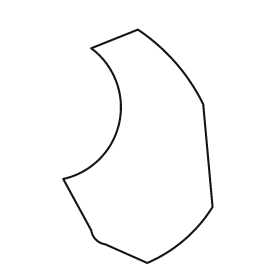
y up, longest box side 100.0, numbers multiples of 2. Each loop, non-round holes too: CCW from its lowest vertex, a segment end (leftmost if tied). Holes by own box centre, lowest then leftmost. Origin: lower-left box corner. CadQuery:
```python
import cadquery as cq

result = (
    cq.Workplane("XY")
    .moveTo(36.0, 0.0)
    .threePointArc((52.0, 10.0), (64.0, 24.0))
    .lineTo(60.0, 68.0)
    .threePointArc((48.0, 86.0), (32.0, 100.0))
    .lineTo(12.0, 92.0)
    .threePointArc((24.0, 60.0), (0.0, 36.0))
    .lineTo(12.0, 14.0)
    .threePointArc((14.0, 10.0), (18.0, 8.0))
    .close()
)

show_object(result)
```